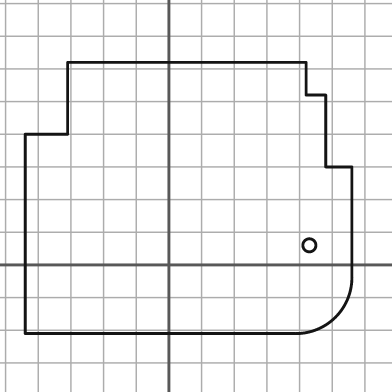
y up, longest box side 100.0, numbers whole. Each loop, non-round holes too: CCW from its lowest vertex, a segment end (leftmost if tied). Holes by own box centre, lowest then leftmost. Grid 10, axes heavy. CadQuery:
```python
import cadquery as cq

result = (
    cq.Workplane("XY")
    .moveTo(-44.0, -21.0)
    .lineTo(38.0, -21.0)
    .threePointArc((51.0, -16.0), (56.0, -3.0))
    .lineTo(56.0, 30.0)
    .lineTo(48.0, 30.0)
    .lineTo(48.0, 52.0)
    .lineTo(42.0, 52.0)
    .lineTo(42.0, 62.0)
    .lineTo(-31.0, 62.0)
    .lineTo(-31.0, 40.0)
    .lineTo(-44.0, 40.0)
    .close()
    .moveTo(43.0, 6.0)
    .circle(2.0)
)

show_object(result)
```